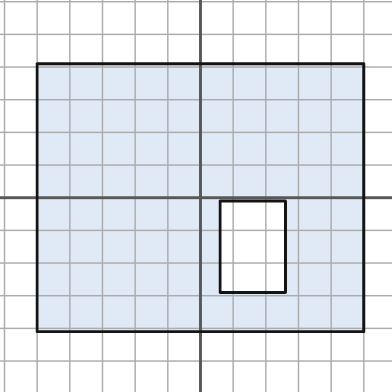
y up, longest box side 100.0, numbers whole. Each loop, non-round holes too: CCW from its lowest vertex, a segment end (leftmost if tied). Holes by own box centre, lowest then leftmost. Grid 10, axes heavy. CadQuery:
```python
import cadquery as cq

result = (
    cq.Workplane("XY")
    .moveTo(-50.0, -41.0)
    .lineTo(50.0, -41.0)
    .lineTo(50.0, 41.0)
    .lineTo(-50.0, 41.0)
    .close()
    .moveTo(6.0, -29.0)
    .lineTo(26.0, -29.0)
    .lineTo(26.0, -1.0)
    .lineTo(6.0, -1.0)
    .close()
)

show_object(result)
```